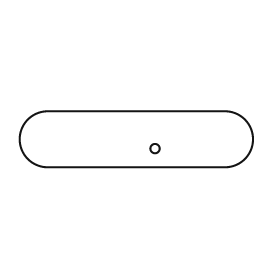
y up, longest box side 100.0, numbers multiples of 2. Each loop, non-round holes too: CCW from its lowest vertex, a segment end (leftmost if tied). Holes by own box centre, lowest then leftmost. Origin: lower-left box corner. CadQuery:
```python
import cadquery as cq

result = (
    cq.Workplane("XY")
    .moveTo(12.0, 0.0)
    .lineTo(88.0, 0.0)
    .threePointArc((100.0, 12.0), (88.0, 24.0))
    .lineTo(12.0, 24.0)
    .threePointArc((0.0, 12.0), (12.0, 0.0))
    .close()
    .moveTo(58.0, 8.0)
    .circle(2.0)
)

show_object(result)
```